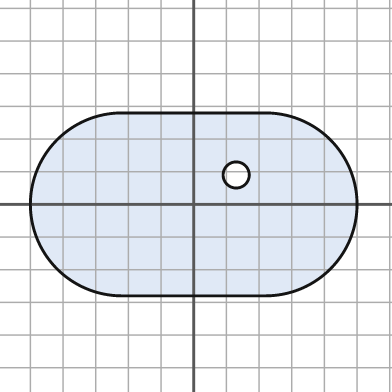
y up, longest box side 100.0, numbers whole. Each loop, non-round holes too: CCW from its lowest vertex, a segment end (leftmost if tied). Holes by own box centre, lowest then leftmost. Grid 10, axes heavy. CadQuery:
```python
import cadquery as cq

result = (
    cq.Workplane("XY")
    .moveTo(-22.0, -28.0)
    .lineTo(22.0, -28.0)
    .threePointArc((50.0, 0.0), (22.0, 28.0))
    .lineTo(-22.0, 28.0)
    .threePointArc((-50.0, 0.0), (-22.0, -28.0))
    .close()
    .moveTo(13.0, 9.0)
    .circle(4.0)
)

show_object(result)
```